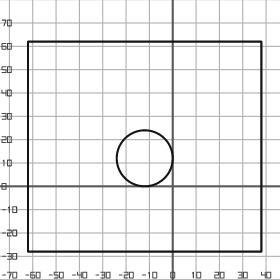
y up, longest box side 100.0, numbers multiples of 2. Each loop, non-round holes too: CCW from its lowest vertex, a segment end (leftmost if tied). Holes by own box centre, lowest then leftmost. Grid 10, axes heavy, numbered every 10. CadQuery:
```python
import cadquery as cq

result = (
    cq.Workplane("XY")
    .moveTo(-62.0, -28.0)
    .lineTo(38.0, -28.0)
    .lineTo(38.0, 62.0)
    .lineTo(-62.0, 62.0)
    .close()
    .moveTo(-12.0, 12.0)
    .circle(12.0)
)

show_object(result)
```